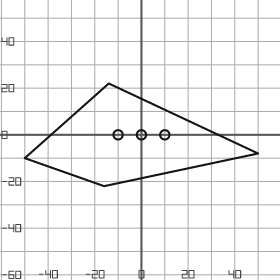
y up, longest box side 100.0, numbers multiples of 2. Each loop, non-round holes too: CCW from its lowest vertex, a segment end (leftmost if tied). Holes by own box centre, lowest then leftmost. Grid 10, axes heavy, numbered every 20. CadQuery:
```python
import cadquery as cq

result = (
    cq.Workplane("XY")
    .moveTo(-16.0, -22.0)
    .lineTo(50.0, -8.0)
    .lineTo(-14.0, 22.0)
    .lineTo(-50.0, -10.0)
    .close()
    .moveTo(-10.0, 0.0)
    .circle(2.0)
    .moveTo(0.0, 0.0)
    .circle(2.0)
    .moveTo(10.0, 0.0)
    .circle(2.0)
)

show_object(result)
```